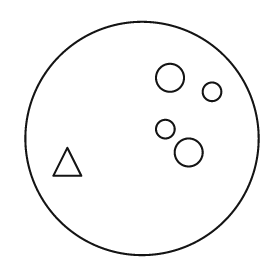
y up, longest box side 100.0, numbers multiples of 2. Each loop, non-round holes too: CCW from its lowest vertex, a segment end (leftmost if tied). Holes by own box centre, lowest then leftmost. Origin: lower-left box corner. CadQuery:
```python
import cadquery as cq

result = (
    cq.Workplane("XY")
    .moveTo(50.0, 50.0)
    .circle(50.0)
    .moveTo(12.0, 34.0)
    .lineTo(24.0, 34.0)
    .lineTo(18.0, 46.0)
    .close()
    .moveTo(70.0, 44.0)
    .circle(6.0)
    .moveTo(60.0, 54.0)
    .circle(4.0)
    .moveTo(80.0, 70.0)
    .circle(4.0)
    .moveTo(62.0, 76.0)
    .circle(6.0)
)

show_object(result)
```